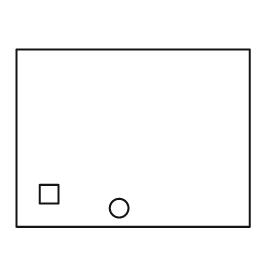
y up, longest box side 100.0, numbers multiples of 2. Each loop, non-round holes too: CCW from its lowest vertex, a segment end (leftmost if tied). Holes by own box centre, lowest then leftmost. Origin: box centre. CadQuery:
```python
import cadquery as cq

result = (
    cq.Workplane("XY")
    .moveTo(-50.0, -38.0)
    .lineTo(50.0, -38.0)
    .lineTo(50.0, 38.0)
    .lineTo(-50.0, 38.0)
    .close()
    .moveTo(-6.0, -30.0)
    .circle(4.0)
    .moveTo(-40.0, -28.0)
    .lineTo(-32.0, -28.0)
    .lineTo(-32.0, -20.0)
    .lineTo(-40.0, -20.0)
    .close()
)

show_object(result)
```